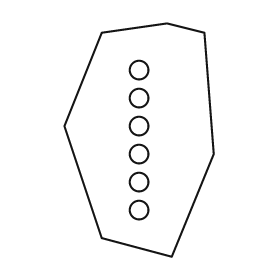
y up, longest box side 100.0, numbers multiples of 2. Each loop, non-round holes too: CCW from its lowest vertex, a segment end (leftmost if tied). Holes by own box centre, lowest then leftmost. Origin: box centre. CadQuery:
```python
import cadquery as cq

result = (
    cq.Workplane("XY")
    .moveTo(14.0, -50.0)
    .lineTo(32.0, -6.0)
    .lineTo(28.0, 46.0)
    .lineTo(12.0, 50.0)
    .lineTo(-16.0, 46.0)
    .lineTo(-32.0, 6.0)
    .lineTo(-16.0, -42.0)
    .close()
    .moveTo(0.0, -30.0)
    .circle(4.0)
    .moveTo(0.0, -18.0)
    .circle(4.0)
    .moveTo(0.0, -6.0)
    .circle(4.0)
    .moveTo(0.0, 6.0)
    .circle(4.0)
    .moveTo(0.0, 18.0)
    .circle(4.0)
    .moveTo(0.0, 30.0)
    .circle(4.0)
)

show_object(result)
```